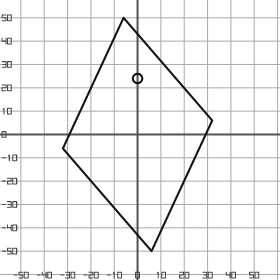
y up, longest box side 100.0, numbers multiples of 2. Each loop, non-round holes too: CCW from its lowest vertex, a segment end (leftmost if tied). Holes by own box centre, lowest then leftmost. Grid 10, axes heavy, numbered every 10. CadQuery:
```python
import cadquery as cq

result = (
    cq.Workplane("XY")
    .moveTo(6.0, -50.0)
    .lineTo(32.0, 6.0)
    .lineTo(-6.0, 50.0)
    .lineTo(-32.0, -6.0)
    .close()
    .moveTo(0.0, 24.0)
    .circle(2.0)
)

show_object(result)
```